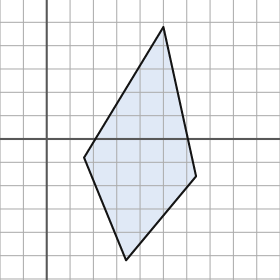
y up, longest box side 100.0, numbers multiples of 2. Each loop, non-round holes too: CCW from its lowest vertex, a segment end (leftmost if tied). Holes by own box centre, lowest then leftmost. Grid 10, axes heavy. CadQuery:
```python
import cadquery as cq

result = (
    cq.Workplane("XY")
    .moveTo(34.0, -52.0)
    .lineTo(64.0, -16.0)
    .lineTo(50.0, 48.0)
    .lineTo(16.0, -8.0)
    .close()
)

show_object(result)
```